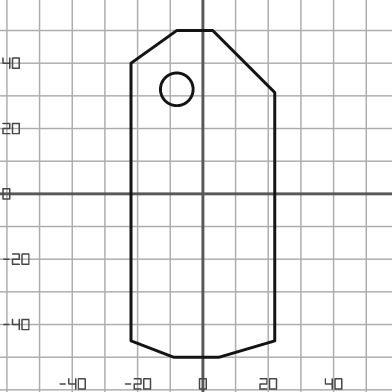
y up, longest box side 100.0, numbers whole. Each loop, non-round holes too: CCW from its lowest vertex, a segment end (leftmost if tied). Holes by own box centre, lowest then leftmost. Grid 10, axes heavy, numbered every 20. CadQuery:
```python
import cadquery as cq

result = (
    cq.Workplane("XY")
    .moveTo(-9.0, -50.0)
    .lineTo(5.0, -50.0)
    .lineTo(22.0, -45.0)
    .lineTo(22.0, 31.0)
    .lineTo(3.0, 50.0)
    .lineTo(-8.0, 50.0)
    .lineTo(-22.0, 40.0)
    .lineTo(-22.0, -45.0)
    .close()
    .moveTo(-8.0, 32.0)
    .circle(5.0)
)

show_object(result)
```